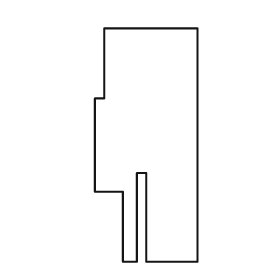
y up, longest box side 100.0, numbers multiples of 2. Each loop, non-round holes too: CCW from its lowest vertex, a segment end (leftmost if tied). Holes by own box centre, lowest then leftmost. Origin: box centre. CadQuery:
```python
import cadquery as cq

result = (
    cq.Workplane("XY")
    .moveTo(-10.0, -50.0)
    .lineTo(-4.0, -50.0)
    .lineTo(-4.0, -12.0)
    .lineTo(0.0, -12.0)
    .lineTo(0.0, -50.0)
    .lineTo(22.0, -50.0)
    .lineTo(22.0, 50.0)
    .lineTo(-18.0, 50.0)
    .lineTo(-18.0, 20.0)
    .lineTo(-22.0, 20.0)
    .lineTo(-22.0, -20.0)
    .lineTo(-10.0, -20.0)
    .close()
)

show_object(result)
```